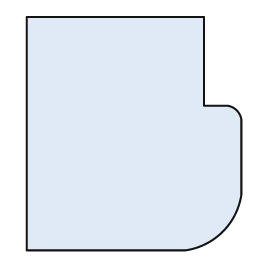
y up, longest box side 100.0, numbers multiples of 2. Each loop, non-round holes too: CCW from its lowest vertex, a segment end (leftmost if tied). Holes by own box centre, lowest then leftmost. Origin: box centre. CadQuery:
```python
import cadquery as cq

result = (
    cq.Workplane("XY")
    .moveTo(-46.0, -50.0)
    .lineTo(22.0, -50.0)
    .threePointArc((38.0, -42.0), (46.0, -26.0))
    .lineTo(46.0, 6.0)
    .threePointArc((44.0, 10.0), (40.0, 12.0))
    .lineTo(30.0, 12.0)
    .lineTo(30.0, 50.0)
    .lineTo(-46.0, 50.0)
    .close()
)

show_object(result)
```